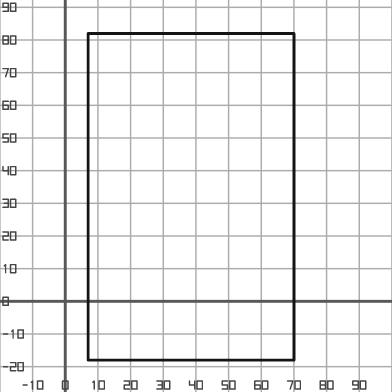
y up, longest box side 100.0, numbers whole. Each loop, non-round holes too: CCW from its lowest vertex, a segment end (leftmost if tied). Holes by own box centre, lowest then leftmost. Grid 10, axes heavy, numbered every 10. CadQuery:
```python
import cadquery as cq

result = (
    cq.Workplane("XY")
    .moveTo(7.0, -18.0)
    .lineTo(70.0, -18.0)
    .lineTo(70.0, 82.0)
    .lineTo(7.0, 82.0)
    .close()
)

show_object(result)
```